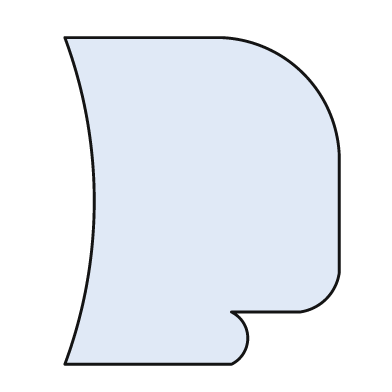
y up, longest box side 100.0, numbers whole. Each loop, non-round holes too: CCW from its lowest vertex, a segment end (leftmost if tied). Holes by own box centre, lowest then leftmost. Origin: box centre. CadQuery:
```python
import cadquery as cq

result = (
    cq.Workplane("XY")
    .moveTo(-42.0, -50.0)
    .lineTo(9.0, -50.0)
    .threePointArc((14.0, -42.0), (9.0, -34.0))
    .lineTo(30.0, -34.0)
    .threePointArc((38.0, -30.0), (42.0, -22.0))
    .lineTo(42.0, 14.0)
    .threePointArc((31.0, 39.0), (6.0, 50.0))
    .lineTo(-42.0, 50.0)
    .threePointArc((-33.0, 0.0), (-42.0, -50.0))
    .close()
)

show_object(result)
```